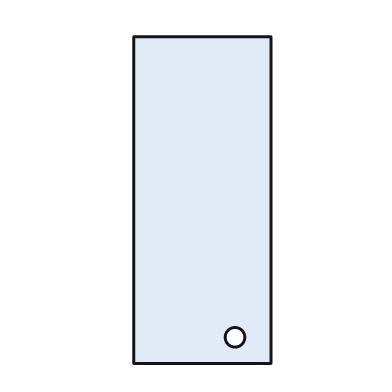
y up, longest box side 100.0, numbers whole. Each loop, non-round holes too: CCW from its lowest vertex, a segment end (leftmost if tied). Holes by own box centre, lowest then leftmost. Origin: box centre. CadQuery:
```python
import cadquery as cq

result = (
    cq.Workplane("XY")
    .moveTo(-21.0, -50.0)
    .lineTo(21.0, -50.0)
    .lineTo(21.0, 50.0)
    .lineTo(-21.0, 50.0)
    .close()
    .moveTo(10.0, -42.0)
    .circle(3.0)
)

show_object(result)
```